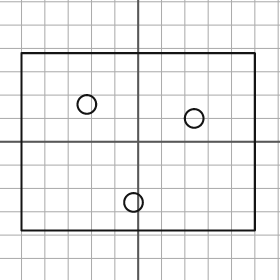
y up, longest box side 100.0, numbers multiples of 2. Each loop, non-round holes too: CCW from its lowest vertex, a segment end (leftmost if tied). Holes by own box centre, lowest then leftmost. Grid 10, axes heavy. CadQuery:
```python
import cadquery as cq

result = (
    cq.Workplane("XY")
    .moveTo(-50.0, -38.0)
    .lineTo(50.0, -38.0)
    .lineTo(50.0, 38.0)
    .lineTo(-50.0, 38.0)
    .close()
    .moveTo(-2.0, -26.0)
    .circle(4.0)
    .moveTo(24.0, 10.0)
    .circle(4.0)
    .moveTo(-22.0, 16.0)
    .circle(4.0)
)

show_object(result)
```